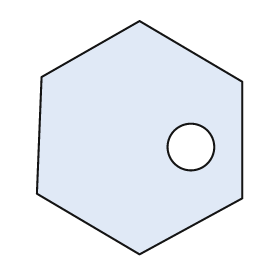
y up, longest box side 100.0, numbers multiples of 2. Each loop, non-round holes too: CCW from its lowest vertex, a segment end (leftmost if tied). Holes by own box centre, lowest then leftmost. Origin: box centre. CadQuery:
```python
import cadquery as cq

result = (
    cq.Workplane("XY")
    .moveTo(0.0, -50.0)
    .lineTo(44.0, -26.0)
    .lineTo(44.0, 24.0)
    .lineTo(0.0, 50.0)
    .lineTo(-42.0, 26.0)
    .lineTo(-44.0, -24.0)
    .close()
    .moveTo(22.0, -4.0)
    .circle(10.0)
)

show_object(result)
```